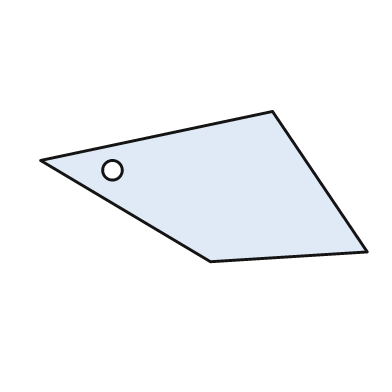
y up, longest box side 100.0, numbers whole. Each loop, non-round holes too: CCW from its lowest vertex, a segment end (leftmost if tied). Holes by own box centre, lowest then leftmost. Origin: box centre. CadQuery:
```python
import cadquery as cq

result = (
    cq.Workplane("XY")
    .moveTo(2.0, -23.0)
    .lineTo(50.0, -20.0)
    .lineTo(21.0, 23.0)
    .lineTo(-50.0, 8.0)
    .close()
    .moveTo(-28.0, 5.0)
    .circle(3.0)
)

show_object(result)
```